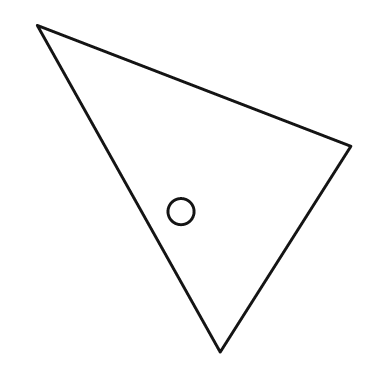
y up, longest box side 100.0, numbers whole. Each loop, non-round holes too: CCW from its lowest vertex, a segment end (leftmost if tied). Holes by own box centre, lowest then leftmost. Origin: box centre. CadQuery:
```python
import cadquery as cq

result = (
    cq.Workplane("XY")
    .moveTo(8.0, -50.0)
    .lineTo(48.0, 13.0)
    .lineTo(-48.0, 50.0)
    .close()
    .moveTo(-4.0, -7.0)
    .circle(4.0)
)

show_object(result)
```